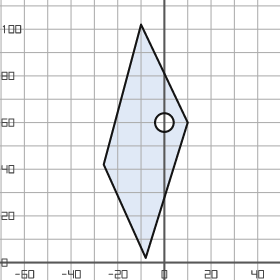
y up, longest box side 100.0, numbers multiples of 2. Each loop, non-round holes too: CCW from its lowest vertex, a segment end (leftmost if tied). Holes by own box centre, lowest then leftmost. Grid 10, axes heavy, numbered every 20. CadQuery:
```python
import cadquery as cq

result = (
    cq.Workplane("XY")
    .moveTo(-8.0, 2.0)
    .lineTo(10.0, 60.0)
    .lineTo(-10.0, 102.0)
    .lineTo(-26.0, 42.0)
    .close()
    .moveTo(0.0, 60.0)
    .circle(4.0)
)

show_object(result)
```